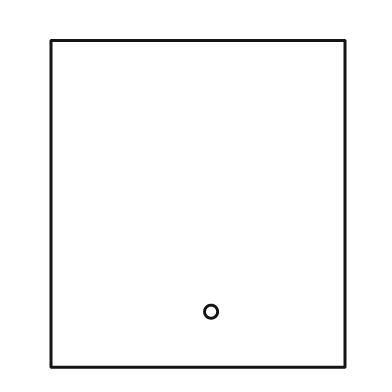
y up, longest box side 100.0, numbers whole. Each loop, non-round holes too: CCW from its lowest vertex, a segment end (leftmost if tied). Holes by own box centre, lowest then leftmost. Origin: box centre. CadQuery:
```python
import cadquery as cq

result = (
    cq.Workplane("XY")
    .moveTo(-45.0, -50.0)
    .lineTo(45.0, -50.0)
    .lineTo(45.0, 50.0)
    .lineTo(-45.0, 50.0)
    .close()
    .moveTo(4.0, -33.0)
    .circle(2.0)
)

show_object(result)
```